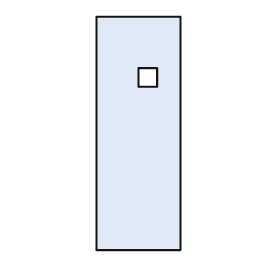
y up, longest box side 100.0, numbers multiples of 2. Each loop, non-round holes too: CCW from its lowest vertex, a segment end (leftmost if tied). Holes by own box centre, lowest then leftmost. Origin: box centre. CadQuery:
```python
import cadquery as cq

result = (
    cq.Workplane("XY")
    .moveTo(-18.0, -50.0)
    .lineTo(18.0, -50.0)
    .lineTo(18.0, 50.0)
    .lineTo(-18.0, 50.0)
    .close()
    .moveTo(0.0, 20.0)
    .lineTo(8.0, 20.0)
    .lineTo(8.0, 28.0)
    .lineTo(0.0, 28.0)
    .close()
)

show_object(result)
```